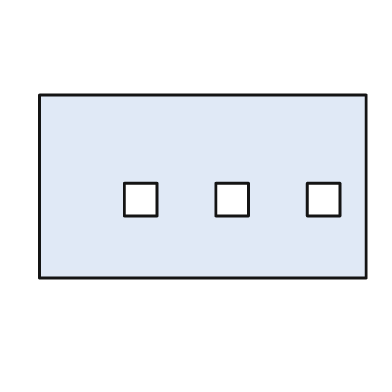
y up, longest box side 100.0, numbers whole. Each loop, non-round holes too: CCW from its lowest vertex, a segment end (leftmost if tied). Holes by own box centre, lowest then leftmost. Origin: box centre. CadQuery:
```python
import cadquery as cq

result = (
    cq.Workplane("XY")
    .moveTo(-50.0, -28.0)
    .lineTo(50.0, -28.0)
    .lineTo(50.0, 28.0)
    .lineTo(-50.0, 28.0)
    .close()
    .moveTo(-24.0, -9.0)
    .lineTo(-14.0, -9.0)
    .lineTo(-14.0, 1.0)
    .lineTo(-24.0, 1.0)
    .close()
    .moveTo(4.0, -9.0)
    .lineTo(14.0, -9.0)
    .lineTo(14.0, 1.0)
    .lineTo(4.0, 1.0)
    .close()
    .moveTo(32.0, -9.0)
    .lineTo(42.0, -9.0)
    .lineTo(42.0, 1.0)
    .lineTo(32.0, 1.0)
    .close()
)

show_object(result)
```